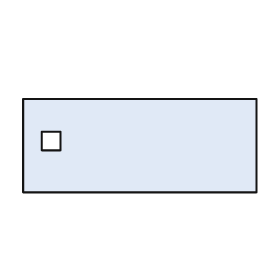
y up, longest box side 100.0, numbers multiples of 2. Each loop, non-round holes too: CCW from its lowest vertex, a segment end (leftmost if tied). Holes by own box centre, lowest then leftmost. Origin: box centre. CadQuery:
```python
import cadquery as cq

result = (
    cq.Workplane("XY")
    .moveTo(-50.0, -20.0)
    .lineTo(50.0, -20.0)
    .lineTo(50.0, 20.0)
    .lineTo(-50.0, 20.0)
    .close()
    .moveTo(-42.0, -2.0)
    .lineTo(-34.0, -2.0)
    .lineTo(-34.0, 6.0)
    .lineTo(-42.0, 6.0)
    .close()
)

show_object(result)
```